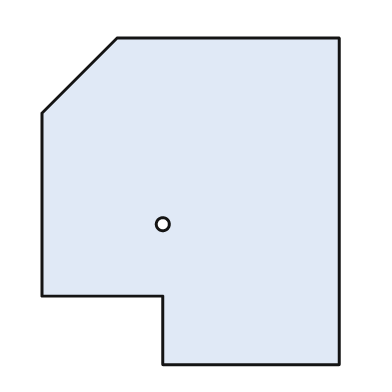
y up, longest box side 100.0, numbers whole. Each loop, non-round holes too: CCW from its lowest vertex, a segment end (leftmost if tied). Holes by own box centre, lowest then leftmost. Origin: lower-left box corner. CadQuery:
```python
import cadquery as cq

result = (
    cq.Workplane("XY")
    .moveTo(37.0, 0.0)
    .lineTo(91.0, 0.0)
    .lineTo(91.0, 100.0)
    .lineTo(23.0, 100.0)
    .lineTo(0.0, 77.0)
    .lineTo(0.0, 21.0)
    .lineTo(37.0, 21.0)
    .close()
    .moveTo(37.0, 43.0)
    .circle(2.0)
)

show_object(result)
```